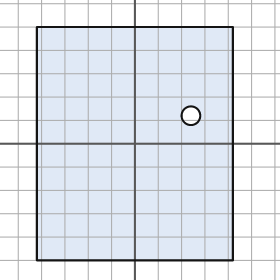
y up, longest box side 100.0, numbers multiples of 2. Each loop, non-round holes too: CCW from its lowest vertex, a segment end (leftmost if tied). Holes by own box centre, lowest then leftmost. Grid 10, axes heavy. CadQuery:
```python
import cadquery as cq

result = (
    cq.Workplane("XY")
    .moveTo(-42.0, -50.0)
    .lineTo(42.0, -50.0)
    .lineTo(42.0, 50.0)
    .lineTo(-42.0, 50.0)
    .close()
    .moveTo(24.0, 12.0)
    .circle(4.0)
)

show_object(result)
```